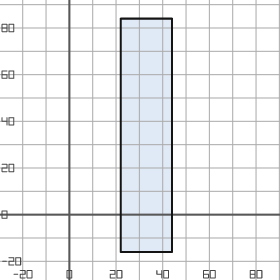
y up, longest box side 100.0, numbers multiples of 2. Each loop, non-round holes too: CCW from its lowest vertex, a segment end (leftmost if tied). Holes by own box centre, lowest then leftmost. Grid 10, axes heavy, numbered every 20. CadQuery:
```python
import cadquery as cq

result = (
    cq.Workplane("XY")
    .moveTo(22.0, -16.0)
    .lineTo(44.0, -16.0)
    .lineTo(44.0, 84.0)
    .lineTo(22.0, 84.0)
    .close()
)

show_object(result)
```